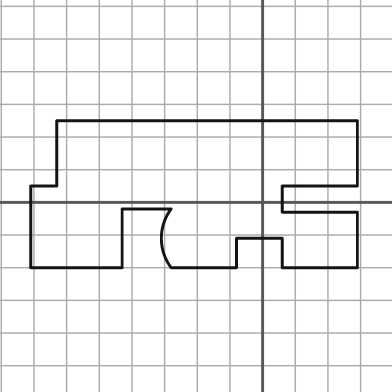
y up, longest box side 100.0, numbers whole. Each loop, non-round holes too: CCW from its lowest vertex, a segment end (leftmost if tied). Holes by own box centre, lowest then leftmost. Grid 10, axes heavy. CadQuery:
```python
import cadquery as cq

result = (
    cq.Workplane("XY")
    .moveTo(-71.0, -20.0)
    .lineTo(-43.0, -20.0)
    .lineTo(-43.0, -2.0)
    .lineTo(-28.0, -2.0)
    .threePointArc((-31.0, -11.0), (-28.0, -20.0))
    .lineTo(-8.0, -20.0)
    .lineTo(-8.0, -11.0)
    .lineTo(6.0, -11.0)
    .lineTo(6.0, -20.0)
    .lineTo(29.0, -20.0)
    .lineTo(29.0, -3.0)
    .lineTo(6.0, -3.0)
    .lineTo(6.0, 5.0)
    .lineTo(29.0, 5.0)
    .lineTo(29.0, 25.0)
    .lineTo(-63.0, 25.0)
    .lineTo(-63.0, 5.0)
    .lineTo(-71.0, 5.0)
    .close()
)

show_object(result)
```